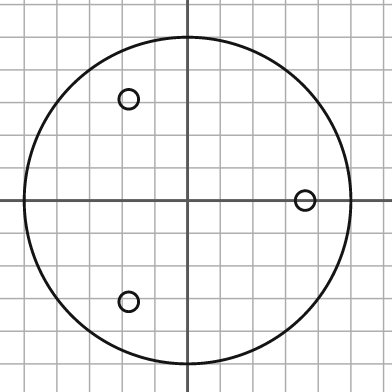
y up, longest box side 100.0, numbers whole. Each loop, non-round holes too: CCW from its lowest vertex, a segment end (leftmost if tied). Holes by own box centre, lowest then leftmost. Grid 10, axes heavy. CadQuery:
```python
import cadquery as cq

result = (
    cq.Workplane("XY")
    .moveTo(0.0, 0.0)
    .circle(50.0)
    .moveTo(-18.0, -31.0)
    .circle(3.0)
    .moveTo(36.0, 0.0)
    .circle(3.0)
    .moveTo(-18.0, 31.0)
    .circle(3.0)
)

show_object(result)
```